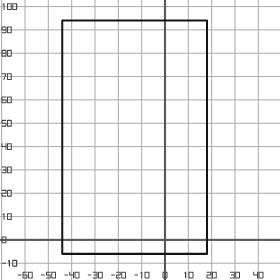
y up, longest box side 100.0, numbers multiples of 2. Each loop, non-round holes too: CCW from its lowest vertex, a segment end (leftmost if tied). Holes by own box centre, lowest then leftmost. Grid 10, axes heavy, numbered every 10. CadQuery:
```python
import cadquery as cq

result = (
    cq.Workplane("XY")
    .moveTo(-44.0, -6.0)
    .lineTo(18.0, -6.0)
    .lineTo(18.0, 94.0)
    .lineTo(-44.0, 94.0)
    .close()
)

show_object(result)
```